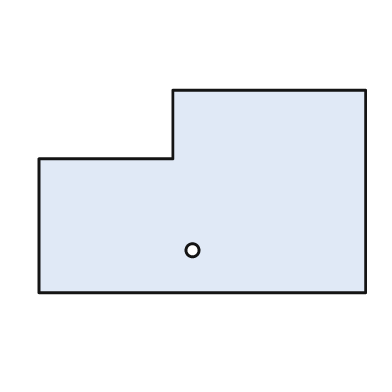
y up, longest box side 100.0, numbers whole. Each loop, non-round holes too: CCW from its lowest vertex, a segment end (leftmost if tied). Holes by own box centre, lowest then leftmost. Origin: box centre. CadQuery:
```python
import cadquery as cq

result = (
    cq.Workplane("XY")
    .moveTo(-50.0, -31.0)
    .lineTo(50.0, -31.0)
    .lineTo(50.0, 31.0)
    .lineTo(-9.0, 31.0)
    .lineTo(-9.0, 10.0)
    .lineTo(-50.0, 10.0)
    .close()
    .moveTo(-3.0, -18.0)
    .circle(2.0)
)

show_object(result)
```